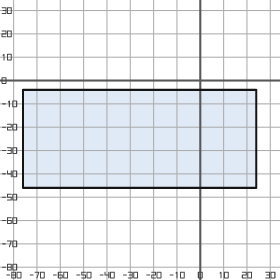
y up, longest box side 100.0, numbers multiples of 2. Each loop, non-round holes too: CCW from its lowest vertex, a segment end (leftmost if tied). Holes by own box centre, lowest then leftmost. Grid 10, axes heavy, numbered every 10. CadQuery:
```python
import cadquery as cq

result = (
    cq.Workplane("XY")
    .moveTo(-76.0, -46.0)
    .lineTo(24.0, -46.0)
    .lineTo(24.0, -4.0)
    .lineTo(-76.0, -4.0)
    .close()
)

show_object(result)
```